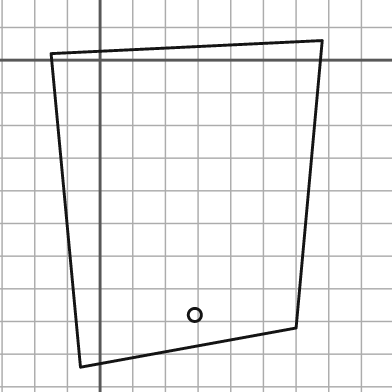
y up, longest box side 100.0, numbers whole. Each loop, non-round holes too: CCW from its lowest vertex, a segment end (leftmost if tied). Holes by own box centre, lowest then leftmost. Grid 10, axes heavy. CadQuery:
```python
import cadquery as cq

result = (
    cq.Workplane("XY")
    .moveTo(-6.0, -94.0)
    .lineTo(60.0, -82.0)
    .lineTo(68.0, 6.0)
    .lineTo(-15.0, 2.0)
    .close()
    .moveTo(29.0, -78.0)
    .circle(2.0)
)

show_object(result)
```